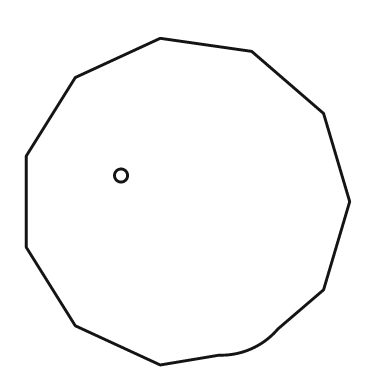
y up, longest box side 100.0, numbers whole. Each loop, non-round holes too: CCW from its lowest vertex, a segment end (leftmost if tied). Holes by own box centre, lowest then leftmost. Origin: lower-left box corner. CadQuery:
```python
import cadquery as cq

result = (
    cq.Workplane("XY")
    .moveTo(41.0, 0.0)
    .lineTo(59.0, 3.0)
    .threePointArc((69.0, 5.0), (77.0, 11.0))
    .lineTo(91.0, 23.0)
    .lineTo(99.0, 50.0)
    .lineTo(91.0, 77.0)
    .lineTo(69.0, 96.0)
    .lineTo(41.0, 100.0)
    .lineTo(15.0, 88.0)
    .lineTo(0.0, 64.0)
    .lineTo(0.0, 36.0)
    .lineTo(15.0, 12.0)
    .close()
    .moveTo(29.0, 58.0)
    .circle(2.0)
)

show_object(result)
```